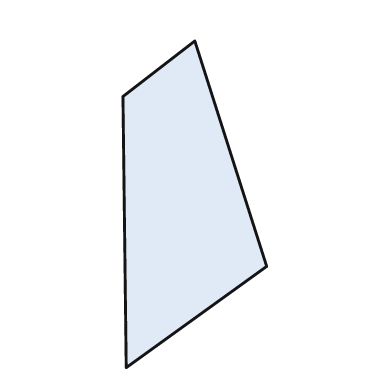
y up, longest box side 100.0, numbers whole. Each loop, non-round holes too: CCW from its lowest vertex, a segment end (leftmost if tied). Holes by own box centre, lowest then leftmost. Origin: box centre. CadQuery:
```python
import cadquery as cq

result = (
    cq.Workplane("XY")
    .moveTo(-21.0, -50.0)
    .lineTo(22.0, -19.0)
    .lineTo(0.0, 50.0)
    .lineTo(-22.0, 33.0)
    .close()
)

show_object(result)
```